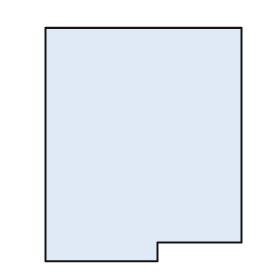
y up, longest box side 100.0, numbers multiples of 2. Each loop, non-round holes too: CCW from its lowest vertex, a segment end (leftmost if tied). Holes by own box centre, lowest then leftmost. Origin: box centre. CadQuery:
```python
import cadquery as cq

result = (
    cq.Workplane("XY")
    .moveTo(-42.0, -50.0)
    .lineTo(6.0, -50.0)
    .lineTo(6.0, -42.0)
    .lineTo(42.0, -42.0)
    .lineTo(42.0, 50.0)
    .lineTo(-42.0, 50.0)
    .close()
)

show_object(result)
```